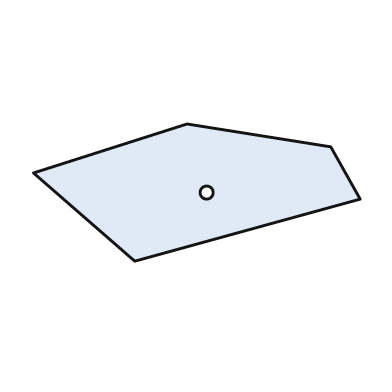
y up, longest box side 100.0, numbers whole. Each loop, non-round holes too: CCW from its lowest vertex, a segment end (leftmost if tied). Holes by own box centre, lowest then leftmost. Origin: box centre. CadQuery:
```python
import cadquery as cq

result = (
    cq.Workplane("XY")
    .moveTo(-19.0, -21.0)
    .lineTo(50.0, -2.0)
    .lineTo(41.0, 14.0)
    .lineTo(-3.0, 21.0)
    .lineTo(-50.0, 6.0)
    .close()
    .moveTo(3.0, 0.0)
    .circle(2.0)
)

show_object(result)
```